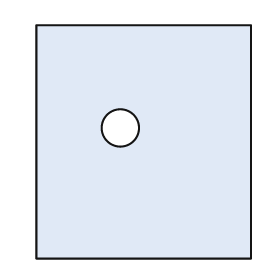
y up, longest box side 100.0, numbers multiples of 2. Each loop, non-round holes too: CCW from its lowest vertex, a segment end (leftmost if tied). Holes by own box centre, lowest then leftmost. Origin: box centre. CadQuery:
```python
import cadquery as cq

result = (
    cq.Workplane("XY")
    .moveTo(-46.0, -50.0)
    .lineTo(46.0, -50.0)
    .lineTo(46.0, 50.0)
    .lineTo(-46.0, 50.0)
    .close()
    .moveTo(-10.0, 6.0)
    .circle(8.0)
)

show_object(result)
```